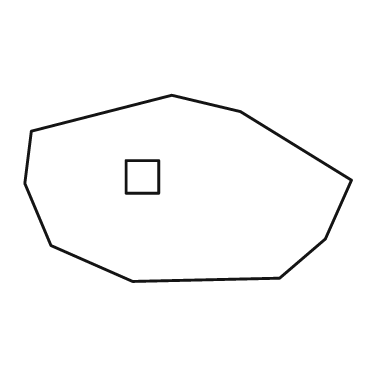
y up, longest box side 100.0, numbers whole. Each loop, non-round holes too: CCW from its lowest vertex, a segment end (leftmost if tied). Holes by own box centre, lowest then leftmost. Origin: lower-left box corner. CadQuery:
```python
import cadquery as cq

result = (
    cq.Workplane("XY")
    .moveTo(33.0, 0.0)
    .lineTo(78.0, 1.0)
    .lineTo(92.0, 13.0)
    .lineTo(100.0, 31.0)
    .lineTo(66.0, 52.0)
    .lineTo(45.0, 57.0)
    .lineTo(2.0, 46.0)
    .lineTo(0.0, 30.0)
    .lineTo(8.0, 11.0)
    .close()
    .moveTo(31.0, 27.0)
    .lineTo(41.0, 27.0)
    .lineTo(41.0, 37.0)
    .lineTo(31.0, 37.0)
    .close()
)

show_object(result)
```